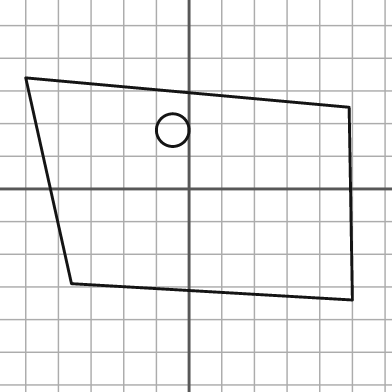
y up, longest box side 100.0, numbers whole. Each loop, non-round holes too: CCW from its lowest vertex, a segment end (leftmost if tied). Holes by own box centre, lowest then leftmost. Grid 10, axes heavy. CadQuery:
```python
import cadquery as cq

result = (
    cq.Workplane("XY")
    .moveTo(50.0, -34.0)
    .lineTo(49.0, 25.0)
    .lineTo(-50.0, 34.0)
    .lineTo(-36.0, -29.0)
    .close()
    .moveTo(-5.0, 18.0)
    .circle(5.0)
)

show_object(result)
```